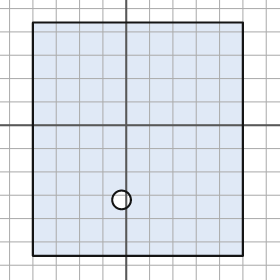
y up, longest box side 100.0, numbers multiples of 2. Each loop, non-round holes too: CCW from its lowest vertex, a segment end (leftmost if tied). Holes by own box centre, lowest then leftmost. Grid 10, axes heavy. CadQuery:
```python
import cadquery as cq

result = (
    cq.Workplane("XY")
    .moveTo(-40.0, -56.0)
    .lineTo(50.0, -56.0)
    .lineTo(50.0, 44.0)
    .lineTo(-40.0, 44.0)
    .close()
    .moveTo(-2.0, -32.0)
    .circle(4.0)
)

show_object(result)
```